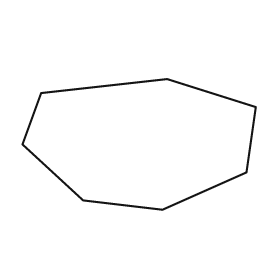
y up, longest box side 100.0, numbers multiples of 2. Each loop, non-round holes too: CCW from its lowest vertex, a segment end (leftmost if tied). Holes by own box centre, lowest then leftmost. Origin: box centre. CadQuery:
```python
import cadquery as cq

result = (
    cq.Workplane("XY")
    .moveTo(10.0, -28.0)
    .lineTo(46.0, -12.0)
    .lineTo(50.0, 16.0)
    .lineTo(12.0, 28.0)
    .lineTo(-42.0, 22.0)
    .lineTo(-50.0, 0.0)
    .lineTo(-24.0, -24.0)
    .close()
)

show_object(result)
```